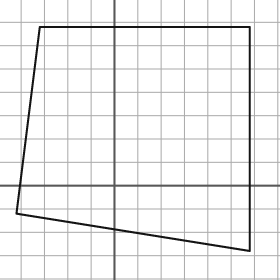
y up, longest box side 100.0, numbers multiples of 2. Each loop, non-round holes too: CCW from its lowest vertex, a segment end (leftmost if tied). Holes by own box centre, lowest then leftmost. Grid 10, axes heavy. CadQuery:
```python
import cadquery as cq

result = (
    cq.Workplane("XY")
    .moveTo(58.0, -28.0)
    .lineTo(58.0, 68.0)
    .lineTo(-32.0, 68.0)
    .lineTo(-42.0, -12.0)
    .close()
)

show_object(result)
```